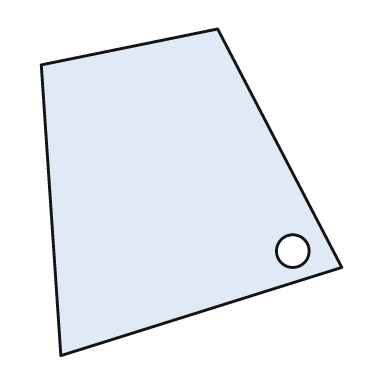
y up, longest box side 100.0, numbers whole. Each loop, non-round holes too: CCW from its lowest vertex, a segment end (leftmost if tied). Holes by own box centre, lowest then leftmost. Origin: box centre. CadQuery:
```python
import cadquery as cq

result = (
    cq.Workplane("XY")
    .moveTo(-40.0, -50.0)
    .lineTo(46.0, -23.0)
    .lineTo(8.0, 50.0)
    .lineTo(-46.0, 39.0)
    .close()
    .moveTo(31.0, -18.0)
    .circle(5.0)
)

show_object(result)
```